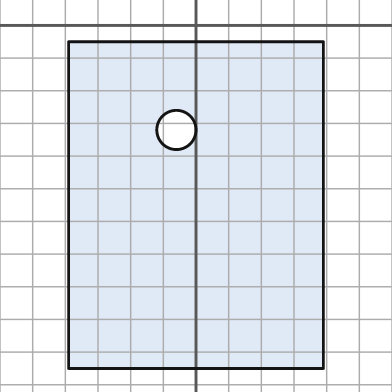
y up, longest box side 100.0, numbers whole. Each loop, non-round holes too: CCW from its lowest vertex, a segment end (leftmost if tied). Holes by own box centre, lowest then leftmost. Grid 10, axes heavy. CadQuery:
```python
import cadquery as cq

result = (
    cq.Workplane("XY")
    .moveTo(-39.0, -105.0)
    .lineTo(39.0, -105.0)
    .lineTo(39.0, -5.0)
    .lineTo(-39.0, -5.0)
    .close()
    .moveTo(-6.0, -32.0)
    .circle(6.0)
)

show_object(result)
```